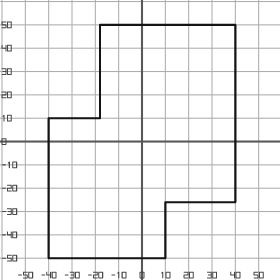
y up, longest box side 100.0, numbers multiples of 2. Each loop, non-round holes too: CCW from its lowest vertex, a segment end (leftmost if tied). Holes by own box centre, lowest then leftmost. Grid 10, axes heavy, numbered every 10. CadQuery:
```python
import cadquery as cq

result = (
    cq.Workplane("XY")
    .moveTo(-40.0, -50.0)
    .lineTo(10.0, -50.0)
    .lineTo(10.0, -26.0)
    .lineTo(40.0, -26.0)
    .lineTo(40.0, 50.0)
    .lineTo(-18.0, 50.0)
    .lineTo(-18.0, 10.0)
    .lineTo(-40.0, 10.0)
    .close()
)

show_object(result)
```